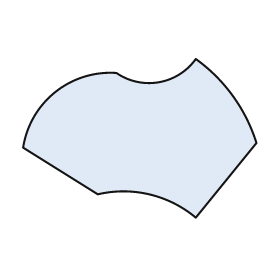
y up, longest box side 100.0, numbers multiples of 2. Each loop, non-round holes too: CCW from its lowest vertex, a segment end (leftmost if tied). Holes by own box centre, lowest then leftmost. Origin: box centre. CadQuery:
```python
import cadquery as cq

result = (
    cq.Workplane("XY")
    .moveTo(24.0, -34.0)
    .lineTo(50.0, -2.0)
    .threePointArc((40.0, 18.0), (24.0, 34.0))
    .threePointArc((8.0, 24.0), (-10.0, 28.0))
    .threePointArc((-36.0, 20.0), (-50.0, -4.0))
    .lineTo(-18.0, -24.0)
    .threePointArc((4.0, -24.0), (24.0, -34.0))
    .close()
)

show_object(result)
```